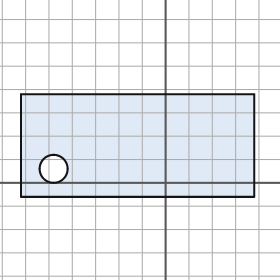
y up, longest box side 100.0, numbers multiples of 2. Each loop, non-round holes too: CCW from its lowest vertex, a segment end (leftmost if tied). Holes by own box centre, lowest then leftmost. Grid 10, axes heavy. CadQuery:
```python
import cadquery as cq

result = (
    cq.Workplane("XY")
    .moveTo(-62.0, -6.0)
    .lineTo(38.0, -6.0)
    .lineTo(38.0, 38.0)
    .lineTo(-62.0, 38.0)
    .close()
    .moveTo(-48.0, 6.0)
    .circle(6.0)
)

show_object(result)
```